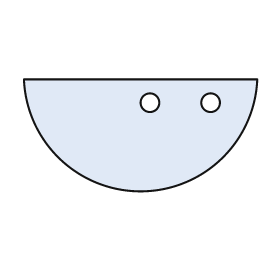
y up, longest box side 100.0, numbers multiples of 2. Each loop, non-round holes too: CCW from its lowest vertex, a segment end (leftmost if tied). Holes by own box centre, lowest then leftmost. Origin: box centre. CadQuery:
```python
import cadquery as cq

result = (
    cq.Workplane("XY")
    .moveTo(-50.0, 24.0)
    .threePointArc((0.0, -24.0), (50.0, 24.0))
    .close()
    .moveTo(4.0, 14.0)
    .circle(4.0)
    .moveTo(30.0, 14.0)
    .circle(4.0)
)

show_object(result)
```